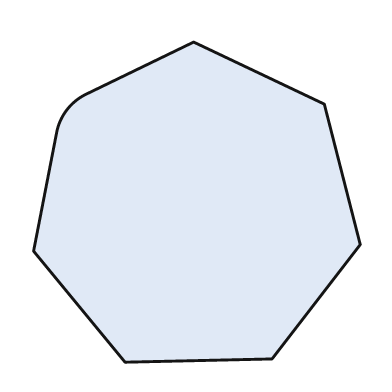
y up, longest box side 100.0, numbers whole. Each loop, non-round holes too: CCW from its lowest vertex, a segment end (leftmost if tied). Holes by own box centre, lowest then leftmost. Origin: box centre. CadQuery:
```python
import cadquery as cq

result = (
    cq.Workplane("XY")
    .moveTo(-22.0, -49.0)
    .lineTo(23.0, -48.0)
    .lineTo(50.0, -13.0)
    .lineTo(39.0, 30.0)
    .lineTo(-1.0, 49.0)
    .lineTo(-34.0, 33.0)
    .threePointArc((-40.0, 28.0), (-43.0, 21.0))
    .lineTo(-50.0, -15.0)
    .close()
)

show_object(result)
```